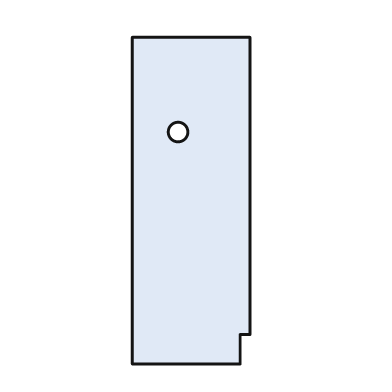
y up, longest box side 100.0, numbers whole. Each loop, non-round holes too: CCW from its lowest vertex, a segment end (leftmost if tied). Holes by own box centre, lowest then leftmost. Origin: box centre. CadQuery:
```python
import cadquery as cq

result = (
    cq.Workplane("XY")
    .moveTo(-18.0, -50.0)
    .lineTo(15.0, -50.0)
    .lineTo(15.0, -41.0)
    .lineTo(18.0, -41.0)
    .lineTo(18.0, 50.0)
    .lineTo(-18.0, 50.0)
    .close()
    .moveTo(-4.0, 21.0)
    .circle(3.0)
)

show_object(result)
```